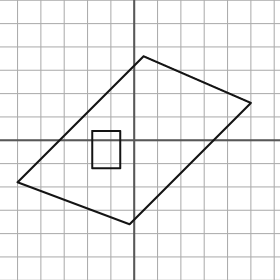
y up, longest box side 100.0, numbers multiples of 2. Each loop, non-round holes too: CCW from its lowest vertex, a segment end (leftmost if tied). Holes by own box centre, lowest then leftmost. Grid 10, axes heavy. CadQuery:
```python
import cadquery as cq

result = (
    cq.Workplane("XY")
    .moveTo(-2.0, -36.0)
    .lineTo(50.0, 16.0)
    .lineTo(4.0, 36.0)
    .lineTo(-50.0, -18.0)
    .close()
    .moveTo(-18.0, -12.0)
    .lineTo(-6.0, -12.0)
    .lineTo(-6.0, 4.0)
    .lineTo(-18.0, 4.0)
    .close()
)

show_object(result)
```